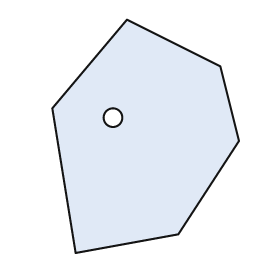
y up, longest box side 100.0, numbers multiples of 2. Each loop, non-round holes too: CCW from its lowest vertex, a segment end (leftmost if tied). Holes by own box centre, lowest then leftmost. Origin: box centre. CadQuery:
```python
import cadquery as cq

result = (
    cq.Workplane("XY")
    .moveTo(-30.0, -50.0)
    .lineTo(14.0, -42.0)
    .lineTo(40.0, -2.0)
    .lineTo(32.0, 30.0)
    .lineTo(-8.0, 50.0)
    .lineTo(-40.0, 12.0)
    .close()
    .moveTo(-14.0, 8.0)
    .circle(4.0)
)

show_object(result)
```